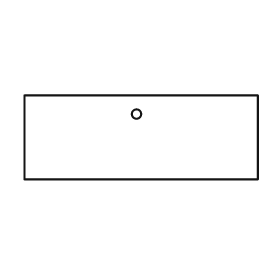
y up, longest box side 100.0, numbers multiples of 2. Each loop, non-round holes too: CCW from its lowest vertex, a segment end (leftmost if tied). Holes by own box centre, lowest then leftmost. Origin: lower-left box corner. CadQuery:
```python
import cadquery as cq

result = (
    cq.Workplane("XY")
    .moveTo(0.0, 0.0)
    .lineTo(100.0, 0.0)
    .lineTo(100.0, 36.0)
    .lineTo(0.0, 36.0)
    .close()
    .moveTo(48.0, 28.0)
    .circle(2.0)
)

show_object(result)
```